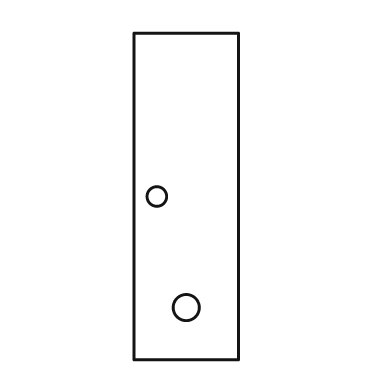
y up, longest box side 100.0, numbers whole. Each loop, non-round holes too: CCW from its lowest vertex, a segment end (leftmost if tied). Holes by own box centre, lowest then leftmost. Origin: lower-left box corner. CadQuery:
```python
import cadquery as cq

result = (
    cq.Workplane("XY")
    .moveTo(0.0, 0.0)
    .lineTo(32.0, 0.0)
    .lineTo(32.0, 100.0)
    .lineTo(0.0, 100.0)
    .close()
    .moveTo(16.0, 16.0)
    .circle(4.0)
    .moveTo(7.0, 50.0)
    .circle(3.0)
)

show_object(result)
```